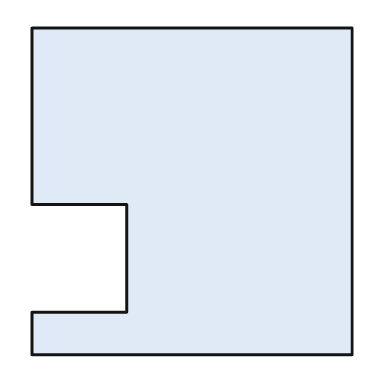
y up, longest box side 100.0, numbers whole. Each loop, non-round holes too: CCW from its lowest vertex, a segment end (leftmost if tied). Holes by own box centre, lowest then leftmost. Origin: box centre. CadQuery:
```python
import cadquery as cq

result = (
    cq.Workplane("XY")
    .moveTo(-49.0, -50.0)
    .lineTo(49.0, -50.0)
    .lineTo(49.0, 50.0)
    .lineTo(-49.0, 50.0)
    .lineTo(-49.0, -4.0)
    .lineTo(-20.0, -4.0)
    .lineTo(-20.0, -37.0)
    .lineTo(-49.0, -37.0)
    .close()
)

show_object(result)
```